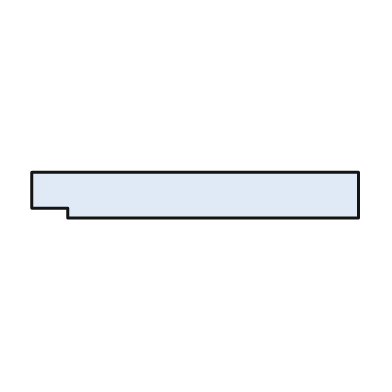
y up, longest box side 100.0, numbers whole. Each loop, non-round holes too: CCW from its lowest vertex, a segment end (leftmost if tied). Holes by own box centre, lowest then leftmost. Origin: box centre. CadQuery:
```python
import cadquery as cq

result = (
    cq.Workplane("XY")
    .moveTo(-39.0, -7.0)
    .lineTo(50.0, -7.0)
    .lineTo(50.0, 7.0)
    .lineTo(-50.0, 7.0)
    .lineTo(-50.0, -4.0)
    .lineTo(-39.0, -4.0)
    .close()
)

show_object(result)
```